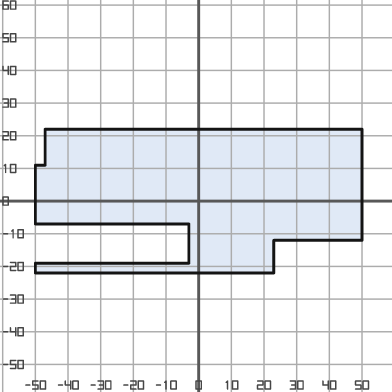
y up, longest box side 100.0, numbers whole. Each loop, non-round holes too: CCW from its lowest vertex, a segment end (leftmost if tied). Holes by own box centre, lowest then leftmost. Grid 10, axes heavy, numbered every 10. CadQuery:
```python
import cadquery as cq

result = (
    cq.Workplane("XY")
    .moveTo(-50.0, -22.0)
    .lineTo(23.0, -22.0)
    .lineTo(23.0, -12.0)
    .lineTo(50.0, -12.0)
    .lineTo(50.0, 22.0)
    .lineTo(-47.0, 22.0)
    .lineTo(-47.0, 11.0)
    .lineTo(-50.0, 11.0)
    .lineTo(-50.0, -7.0)
    .lineTo(-3.0, -7.0)
    .lineTo(-3.0, -19.0)
    .lineTo(-50.0, -19.0)
    .close()
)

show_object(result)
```